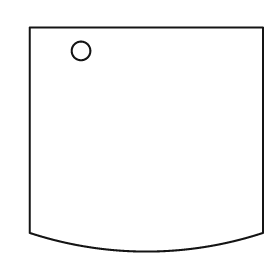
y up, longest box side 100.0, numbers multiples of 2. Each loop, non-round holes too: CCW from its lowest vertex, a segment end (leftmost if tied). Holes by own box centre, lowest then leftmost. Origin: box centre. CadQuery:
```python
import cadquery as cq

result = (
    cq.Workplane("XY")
    .moveTo(-50.0, -40.0)
    .threePointArc((0.0, -48.0), (50.0, -40.0))
    .lineTo(50.0, 48.0)
    .lineTo(-50.0, 48.0)
    .close()
    .moveTo(-28.0, 38.0)
    .circle(4.0)
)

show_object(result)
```